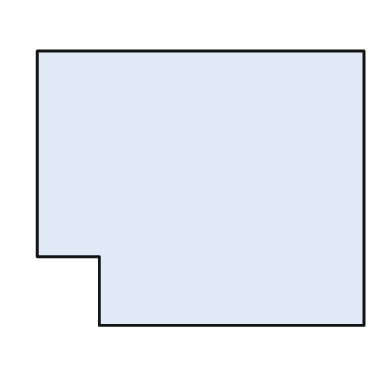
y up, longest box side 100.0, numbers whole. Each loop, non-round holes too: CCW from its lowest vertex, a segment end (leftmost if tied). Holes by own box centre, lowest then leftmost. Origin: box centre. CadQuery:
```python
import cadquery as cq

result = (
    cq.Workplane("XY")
    .moveTo(-31.0, -42.0)
    .lineTo(50.0, -42.0)
    .lineTo(50.0, 42.0)
    .lineTo(-50.0, 42.0)
    .lineTo(-50.0, -21.0)
    .lineTo(-31.0, -21.0)
    .close()
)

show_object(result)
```